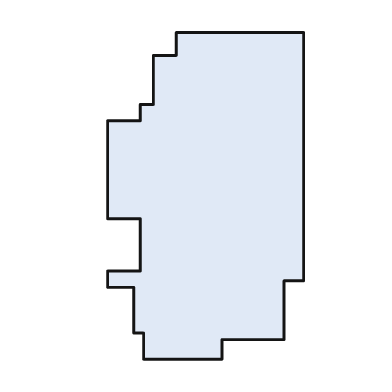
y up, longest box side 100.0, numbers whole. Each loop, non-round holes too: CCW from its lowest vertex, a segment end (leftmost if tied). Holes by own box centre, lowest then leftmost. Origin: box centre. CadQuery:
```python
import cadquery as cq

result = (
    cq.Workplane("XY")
    .moveTo(-19.0, -50.0)
    .lineTo(5.0, -50.0)
    .lineTo(5.0, -44.0)
    .lineTo(24.0, -44.0)
    .lineTo(24.0, -26.0)
    .lineTo(30.0, -26.0)
    .lineTo(30.0, 50.0)
    .lineTo(-9.0, 50.0)
    .lineTo(-9.0, 43.0)
    .lineTo(-16.0, 43.0)
    .lineTo(-16.0, 28.0)
    .lineTo(-20.0, 28.0)
    .lineTo(-20.0, 23.0)
    .lineTo(-30.0, 23.0)
    .lineTo(-30.0, -7.0)
    .lineTo(-20.0, -7.0)
    .lineTo(-20.0, -23.0)
    .lineTo(-30.0, -23.0)
    .lineTo(-30.0, -28.0)
    .lineTo(-22.0, -28.0)
    .lineTo(-22.0, -42.0)
    .lineTo(-19.0, -42.0)
    .close()
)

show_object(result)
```